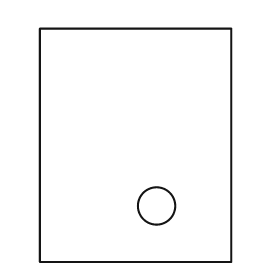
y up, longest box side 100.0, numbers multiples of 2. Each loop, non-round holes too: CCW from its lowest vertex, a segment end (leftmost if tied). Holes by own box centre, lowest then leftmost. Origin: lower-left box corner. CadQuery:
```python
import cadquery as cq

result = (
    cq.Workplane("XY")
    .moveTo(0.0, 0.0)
    .lineTo(82.0, 0.0)
    .lineTo(82.0, 100.0)
    .lineTo(0.0, 100.0)
    .close()
    .moveTo(50.0, 24.0)
    .circle(8.0)
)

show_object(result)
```